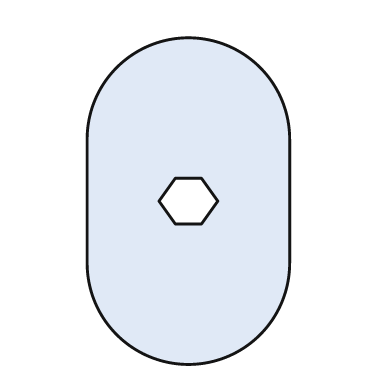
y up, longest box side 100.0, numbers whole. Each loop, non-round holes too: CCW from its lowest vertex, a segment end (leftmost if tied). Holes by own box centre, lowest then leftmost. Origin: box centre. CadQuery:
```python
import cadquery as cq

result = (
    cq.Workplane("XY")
    .moveTo(-31.0, -19.0)
    .threePointArc((0.0, -50.0), (31.0, -19.0))
    .lineTo(31.0, 19.0)
    .threePointArc((0.0, 50.0), (-31.0, 19.0))
    .close()
    .moveTo(-4.0, -7.0)
    .lineTo(4.0, -7.0)
    .lineTo(9.0, 0.0)
    .lineTo(4.0, 7.0)
    .lineTo(-4.0, 7.0)
    .lineTo(-9.0, 0.0)
    .close()
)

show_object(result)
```